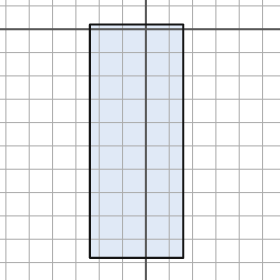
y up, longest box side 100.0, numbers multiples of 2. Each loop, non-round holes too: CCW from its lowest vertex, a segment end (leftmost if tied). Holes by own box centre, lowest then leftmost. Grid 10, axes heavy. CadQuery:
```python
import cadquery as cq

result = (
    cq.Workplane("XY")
    .moveTo(-24.0, -98.0)
    .lineTo(16.0, -98.0)
    .lineTo(16.0, 2.0)
    .lineTo(-24.0, 2.0)
    .close()
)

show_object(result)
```